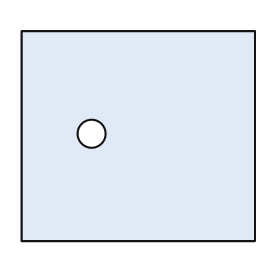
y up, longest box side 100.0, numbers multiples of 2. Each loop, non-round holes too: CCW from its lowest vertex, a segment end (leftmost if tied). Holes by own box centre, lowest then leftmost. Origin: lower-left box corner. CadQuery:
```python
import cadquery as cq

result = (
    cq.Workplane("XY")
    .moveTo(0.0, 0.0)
    .lineTo(100.0, 0.0)
    .lineTo(100.0, 90.0)
    .lineTo(0.0, 90.0)
    .close()
    .moveTo(30.0, 46.0)
    .circle(6.0)
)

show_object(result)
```